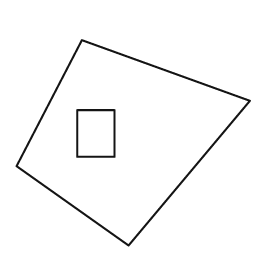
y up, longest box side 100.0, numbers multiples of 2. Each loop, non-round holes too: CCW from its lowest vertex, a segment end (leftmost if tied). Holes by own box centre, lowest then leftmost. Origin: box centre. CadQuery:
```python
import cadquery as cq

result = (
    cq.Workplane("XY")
    .moveTo(-2.0, -44.0)
    .lineTo(50.0, 18.0)
    .lineTo(-22.0, 44.0)
    .lineTo(-50.0, -10.0)
    .close()
    .moveTo(-24.0, -6.0)
    .lineTo(-8.0, -6.0)
    .lineTo(-8.0, 14.0)
    .lineTo(-24.0, 14.0)
    .close()
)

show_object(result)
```